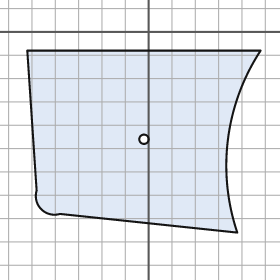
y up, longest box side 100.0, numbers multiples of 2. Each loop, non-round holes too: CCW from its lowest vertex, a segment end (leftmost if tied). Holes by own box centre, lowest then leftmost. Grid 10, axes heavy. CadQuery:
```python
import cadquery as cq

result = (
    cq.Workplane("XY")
    .moveTo(38.0, -86.0)
    .threePointArc((34.0, -46.0), (48.0, -8.0))
    .lineTo(-52.0, -8.0)
    .lineTo(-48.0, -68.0)
    .threePointArc((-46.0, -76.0), (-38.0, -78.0))
    .close()
    .moveTo(-2.0, -46.0)
    .circle(2.0)
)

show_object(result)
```